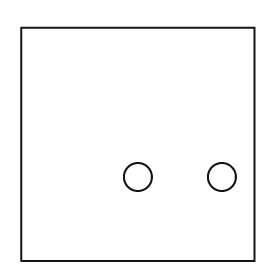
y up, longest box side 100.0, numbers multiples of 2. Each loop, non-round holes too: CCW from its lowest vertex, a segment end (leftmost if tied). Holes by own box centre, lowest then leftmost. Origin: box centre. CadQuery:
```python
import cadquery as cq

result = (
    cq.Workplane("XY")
    .moveTo(-50.0, -50.0)
    .lineTo(50.0, -50.0)
    .lineTo(50.0, 50.0)
    .lineTo(-50.0, 50.0)
    .close()
    .moveTo(0.0, -14.0)
    .circle(6.0)
    .moveTo(36.0, -14.0)
    .circle(6.0)
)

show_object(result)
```